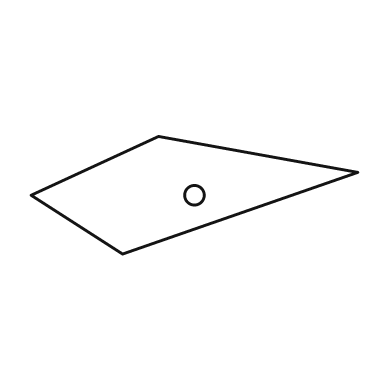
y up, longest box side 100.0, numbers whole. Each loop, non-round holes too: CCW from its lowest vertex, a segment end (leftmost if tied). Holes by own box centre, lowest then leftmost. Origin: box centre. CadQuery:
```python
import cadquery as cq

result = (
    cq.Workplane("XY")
    .moveTo(-22.0, -18.0)
    .lineTo(50.0, 7.0)
    .lineTo(-11.0, 18.0)
    .lineTo(-50.0, 0.0)
    .close()
    .moveTo(0.0, 0.0)
    .circle(3.0)
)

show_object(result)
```